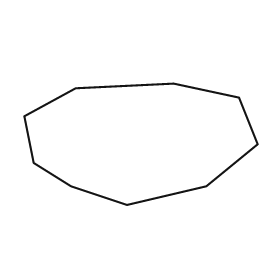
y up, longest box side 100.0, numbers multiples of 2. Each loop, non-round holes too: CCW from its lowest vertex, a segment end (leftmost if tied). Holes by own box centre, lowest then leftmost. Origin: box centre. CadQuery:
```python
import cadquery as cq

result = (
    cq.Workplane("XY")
    .moveTo(-6.0, -26.0)
    .lineTo(28.0, -18.0)
    .lineTo(50.0, 0.0)
    .lineTo(42.0, 20.0)
    .lineTo(14.0, 26.0)
    .lineTo(-28.0, 24.0)
    .lineTo(-50.0, 12.0)
    .lineTo(-46.0, -8.0)
    .lineTo(-30.0, -18.0)
    .close()
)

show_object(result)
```